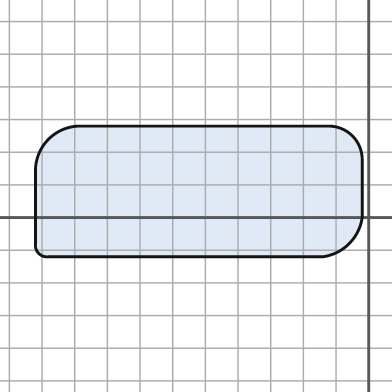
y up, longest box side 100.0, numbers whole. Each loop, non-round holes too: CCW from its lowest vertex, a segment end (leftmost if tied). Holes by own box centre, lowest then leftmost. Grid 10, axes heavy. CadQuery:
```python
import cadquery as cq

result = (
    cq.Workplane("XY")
    .moveTo(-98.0, -12.0)
    .lineTo(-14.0, -12.0)
    .threePointArc((-6.0, -8.0), (-2.0, 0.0))
    .lineTo(-2.0, 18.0)
    .threePointArc((-5.0, 25.0), (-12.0, 28.0))
    .lineTo(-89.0, 28.0)
    .threePointArc((-98.0, 24.0), (-102.0, 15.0))
    .lineTo(-102.0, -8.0)
    .threePointArc((-101.0, -11.0), (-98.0, -12.0))
    .close()
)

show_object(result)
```